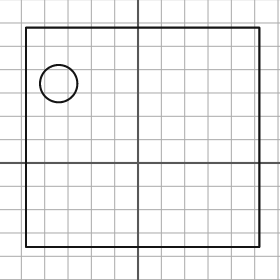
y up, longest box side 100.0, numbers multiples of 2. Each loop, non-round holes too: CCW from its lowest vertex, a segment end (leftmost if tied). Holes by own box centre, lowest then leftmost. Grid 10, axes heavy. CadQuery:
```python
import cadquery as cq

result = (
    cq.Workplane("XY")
    .moveTo(-48.0, -36.0)
    .lineTo(52.0, -36.0)
    .lineTo(52.0, 58.0)
    .lineTo(-48.0, 58.0)
    .close()
    .moveTo(-34.0, 34.0)
    .circle(8.0)
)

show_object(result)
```